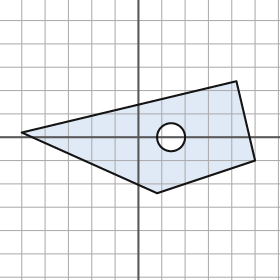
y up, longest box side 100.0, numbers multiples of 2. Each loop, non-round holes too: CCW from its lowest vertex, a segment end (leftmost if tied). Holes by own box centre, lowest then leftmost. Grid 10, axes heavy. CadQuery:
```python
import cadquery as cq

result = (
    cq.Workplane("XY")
    .moveTo(8.0, -24.0)
    .lineTo(50.0, -10.0)
    .lineTo(42.0, 24.0)
    .lineTo(-50.0, 2.0)
    .close()
    .moveTo(14.0, 0.0)
    .circle(6.0)
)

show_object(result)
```